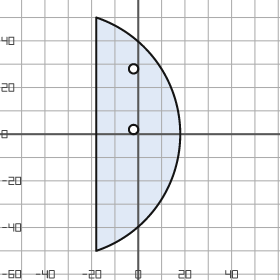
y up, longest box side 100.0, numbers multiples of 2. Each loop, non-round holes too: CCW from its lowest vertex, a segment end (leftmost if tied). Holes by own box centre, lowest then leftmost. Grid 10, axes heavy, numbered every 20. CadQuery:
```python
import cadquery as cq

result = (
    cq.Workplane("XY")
    .moveTo(-18.0, -50.0)
    .threePointArc((18.0, 0.0), (-18.0, 50.0))
    .close()
    .moveTo(-2.0, 2.0)
    .circle(2.0)
    .moveTo(-2.0, 28.0)
    .circle(2.0)
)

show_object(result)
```